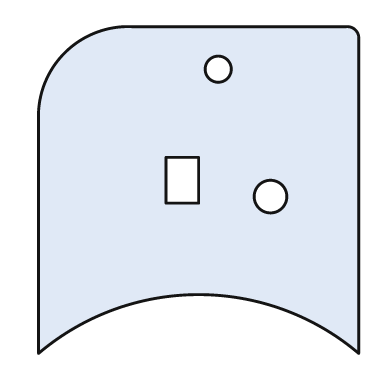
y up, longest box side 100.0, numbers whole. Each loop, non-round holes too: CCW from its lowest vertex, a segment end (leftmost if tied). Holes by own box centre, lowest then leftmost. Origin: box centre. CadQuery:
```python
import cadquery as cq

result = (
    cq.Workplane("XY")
    .moveTo(-49.0, -50.0)
    .threePointArc((0.0, -32.0), (49.0, -50.0))
    .lineTo(49.0, 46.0)
    .threePointArc((48.0, 49.0), (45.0, 50.0))
    .lineTo(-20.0, 50.0)
    .threePointArc((-41.0, 42.0), (-49.0, 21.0))
    .close()
    .moveTo(22.0, -2.0)
    .circle(5.0)
    .moveTo(-10.0, -4.0)
    .lineTo(0.0, -4.0)
    .lineTo(0.0, 10.0)
    .lineTo(-10.0, 10.0)
    .close()
    .moveTo(6.0, 37.0)
    .circle(4.0)
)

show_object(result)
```